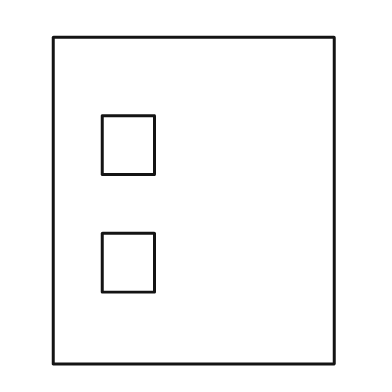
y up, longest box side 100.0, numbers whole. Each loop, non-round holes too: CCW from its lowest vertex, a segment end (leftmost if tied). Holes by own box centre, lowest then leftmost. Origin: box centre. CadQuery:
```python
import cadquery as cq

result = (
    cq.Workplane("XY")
    .moveTo(-43.0, -50.0)
    .lineTo(43.0, -50.0)
    .lineTo(43.0, 50.0)
    .lineTo(-43.0, 50.0)
    .close()
    .moveTo(-28.0, -28.0)
    .lineTo(-12.0, -28.0)
    .lineTo(-12.0, -10.0)
    .lineTo(-28.0, -10.0)
    .close()
    .moveTo(-28.0, 8.0)
    .lineTo(-12.0, 8.0)
    .lineTo(-12.0, 26.0)
    .lineTo(-28.0, 26.0)
    .close()
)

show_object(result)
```